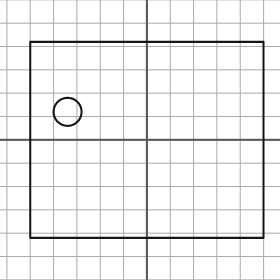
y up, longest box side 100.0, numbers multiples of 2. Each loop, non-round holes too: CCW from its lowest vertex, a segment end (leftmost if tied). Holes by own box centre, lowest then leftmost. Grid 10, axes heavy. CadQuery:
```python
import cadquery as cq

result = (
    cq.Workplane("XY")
    .moveTo(-50.0, -42.0)
    .lineTo(50.0, -42.0)
    .lineTo(50.0, 42.0)
    .lineTo(-50.0, 42.0)
    .close()
    .moveTo(-34.0, 12.0)
    .circle(6.0)
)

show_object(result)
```